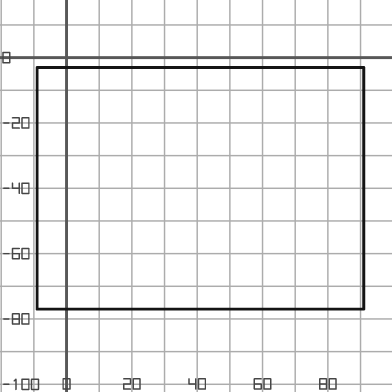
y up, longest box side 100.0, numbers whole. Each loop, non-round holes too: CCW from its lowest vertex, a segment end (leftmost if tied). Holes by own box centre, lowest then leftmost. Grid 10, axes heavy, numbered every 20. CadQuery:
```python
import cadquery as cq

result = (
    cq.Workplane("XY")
    .moveTo(-9.0, -77.0)
    .lineTo(91.0, -77.0)
    .lineTo(91.0, -3.0)
    .lineTo(-9.0, -3.0)
    .close()
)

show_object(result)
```